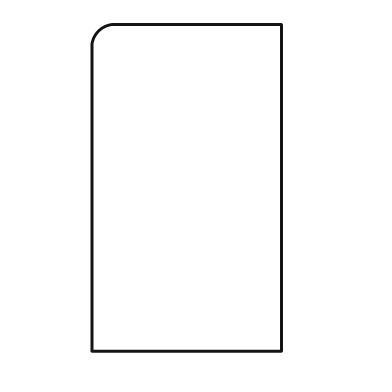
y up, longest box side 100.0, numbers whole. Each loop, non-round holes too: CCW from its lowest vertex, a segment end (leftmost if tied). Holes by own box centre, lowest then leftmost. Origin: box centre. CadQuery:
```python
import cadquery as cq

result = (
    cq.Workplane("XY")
    .moveTo(-29.0, -50.0)
    .lineTo(29.0, -50.0)
    .lineTo(29.0, 50.0)
    .lineTo(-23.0, 50.0)
    .threePointArc((-27.0, 48.0), (-29.0, 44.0))
    .close()
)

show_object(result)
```